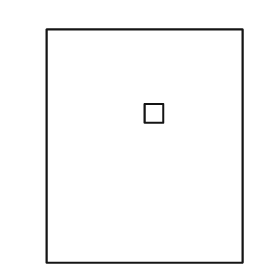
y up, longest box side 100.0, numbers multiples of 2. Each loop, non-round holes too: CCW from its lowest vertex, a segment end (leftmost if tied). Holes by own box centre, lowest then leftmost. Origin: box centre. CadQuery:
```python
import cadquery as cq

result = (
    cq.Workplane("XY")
    .moveTo(-42.0, -50.0)
    .lineTo(42.0, -50.0)
    .lineTo(42.0, 50.0)
    .lineTo(-42.0, 50.0)
    .close()
    .moveTo(0.0, 10.0)
    .lineTo(8.0, 10.0)
    .lineTo(8.0, 18.0)
    .lineTo(0.0, 18.0)
    .close()
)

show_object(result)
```